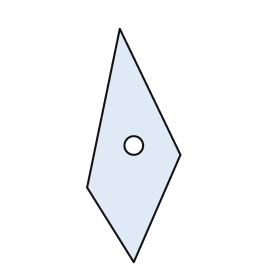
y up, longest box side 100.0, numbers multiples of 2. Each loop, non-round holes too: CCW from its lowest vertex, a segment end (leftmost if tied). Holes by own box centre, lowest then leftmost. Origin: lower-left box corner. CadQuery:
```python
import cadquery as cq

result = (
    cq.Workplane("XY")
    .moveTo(20.0, 0.0)
    .lineTo(40.0, 46.0)
    .lineTo(14.0, 100.0)
    .lineTo(0.0, 32.0)
    .close()
    .moveTo(20.0, 50.0)
    .circle(4.0)
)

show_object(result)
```